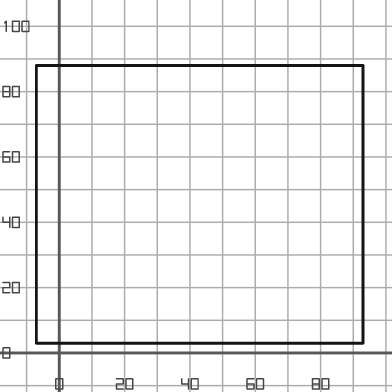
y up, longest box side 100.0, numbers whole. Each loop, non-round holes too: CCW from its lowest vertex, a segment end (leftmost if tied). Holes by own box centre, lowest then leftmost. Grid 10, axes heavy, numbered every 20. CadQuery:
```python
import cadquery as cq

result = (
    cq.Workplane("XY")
    .moveTo(-7.0, 3.0)
    .lineTo(93.0, 3.0)
    .lineTo(93.0, 88.0)
    .lineTo(-7.0, 88.0)
    .close()
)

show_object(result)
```